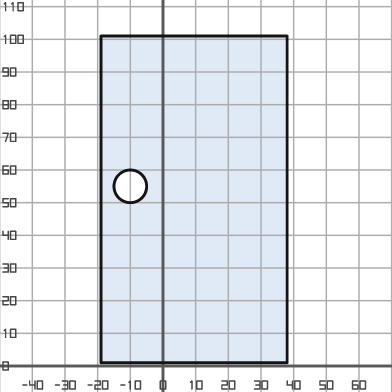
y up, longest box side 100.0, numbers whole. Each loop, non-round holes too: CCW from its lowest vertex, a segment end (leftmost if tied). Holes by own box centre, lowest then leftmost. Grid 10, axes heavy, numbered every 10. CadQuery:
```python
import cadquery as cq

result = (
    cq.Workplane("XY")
    .moveTo(-19.0, 1.0)
    .lineTo(38.0, 1.0)
    .lineTo(38.0, 101.0)
    .lineTo(-19.0, 101.0)
    .close()
    .moveTo(-10.0, 55.0)
    .circle(5.0)
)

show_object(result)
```